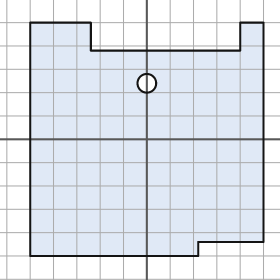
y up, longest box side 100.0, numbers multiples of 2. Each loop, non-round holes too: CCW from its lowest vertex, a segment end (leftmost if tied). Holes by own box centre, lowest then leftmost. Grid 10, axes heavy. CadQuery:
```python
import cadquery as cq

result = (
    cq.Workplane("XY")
    .moveTo(-50.0, -50.0)
    .lineTo(22.0, -50.0)
    .lineTo(22.0, -44.0)
    .lineTo(50.0, -44.0)
    .lineTo(50.0, 50.0)
    .lineTo(40.0, 50.0)
    .lineTo(40.0, 38.0)
    .lineTo(-24.0, 38.0)
    .lineTo(-24.0, 50.0)
    .lineTo(-50.0, 50.0)
    .close()
    .moveTo(0.0, 24.0)
    .circle(4.0)
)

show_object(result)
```